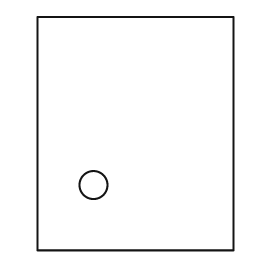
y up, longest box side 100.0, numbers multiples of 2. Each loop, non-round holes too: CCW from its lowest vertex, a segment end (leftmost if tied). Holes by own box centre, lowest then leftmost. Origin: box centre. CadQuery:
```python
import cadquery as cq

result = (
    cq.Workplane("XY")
    .moveTo(-42.0, -50.0)
    .lineTo(42.0, -50.0)
    .lineTo(42.0, 50.0)
    .lineTo(-42.0, 50.0)
    .close()
    .moveTo(-18.0, -22.0)
    .circle(6.0)
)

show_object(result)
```